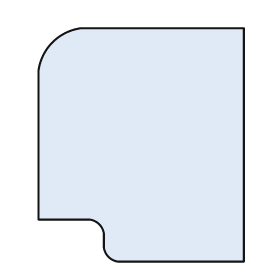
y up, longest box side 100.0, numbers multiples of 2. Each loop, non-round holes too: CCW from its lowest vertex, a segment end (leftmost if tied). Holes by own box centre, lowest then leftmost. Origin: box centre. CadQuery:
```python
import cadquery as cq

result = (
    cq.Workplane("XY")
    .moveTo(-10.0, -50.0)
    .lineTo(44.0, -50.0)
    .lineTo(44.0, 50.0)
    .lineTo(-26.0, 50.0)
    .threePointArc((-38.0, 44.0), (-44.0, 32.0))
    .lineTo(-44.0, -32.0)
    .lineTo(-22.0, -32.0)
    .threePointArc((-18.0, -34.0), (-16.0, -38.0))
    .lineTo(-16.0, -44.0)
    .threePointArc((-14.0, -48.0), (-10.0, -50.0))
    .close()
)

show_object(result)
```